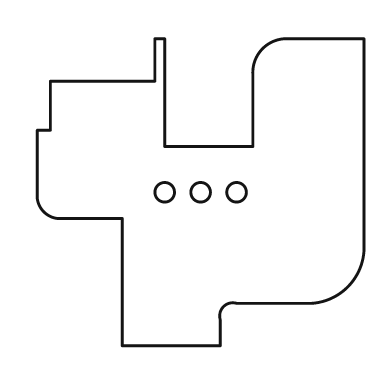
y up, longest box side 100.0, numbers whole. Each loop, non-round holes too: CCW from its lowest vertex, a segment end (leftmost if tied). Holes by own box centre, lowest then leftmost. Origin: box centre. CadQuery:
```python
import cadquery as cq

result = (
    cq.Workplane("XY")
    .moveTo(-24.0, -47.0)
    .lineTo(6.0, -47.0)
    .lineTo(6.0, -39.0)
    .threePointArc((7.0, -35.0), (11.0, -34.0))
    .lineTo(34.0, -34.0)
    .threePointArc((45.0, -29.0), (50.0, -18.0))
    .lineTo(50.0, 47.0)
    .lineTo(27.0, 47.0)
    .threePointArc((19.0, 44.0), (16.0, 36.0))
    .lineTo(16.0, 14.0)
    .lineTo(-11.0, 14.0)
    .lineTo(-11.0, 47.0)
    .lineTo(-14.0, 47.0)
    .lineTo(-14.0, 34.0)
    .lineTo(-46.0, 34.0)
    .lineTo(-46.0, 19.0)
    .lineTo(-50.0, 19.0)
    .lineTo(-50.0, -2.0)
    .threePointArc((-48.0, -6.0), (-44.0, -8.0))
    .lineTo(-24.0, -8.0)
    .close()
    .moveTo(-11.0, 0.0)
    .circle(3.0)
    .moveTo(0.0, 0.0)
    .circle(3.0)
    .moveTo(11.0, 0.0)
    .circle(3.0)
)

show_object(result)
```